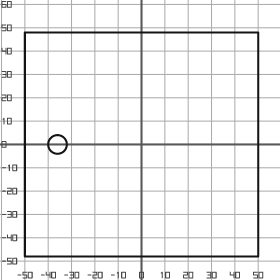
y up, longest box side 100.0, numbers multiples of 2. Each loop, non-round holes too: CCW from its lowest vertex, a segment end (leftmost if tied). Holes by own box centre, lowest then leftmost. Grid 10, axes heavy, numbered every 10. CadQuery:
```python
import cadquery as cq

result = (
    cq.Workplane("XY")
    .moveTo(-50.0, -48.0)
    .lineTo(50.0, -48.0)
    .lineTo(50.0, 48.0)
    .lineTo(-50.0, 48.0)
    .close()
    .moveTo(-36.0, 0.0)
    .circle(4.0)
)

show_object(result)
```